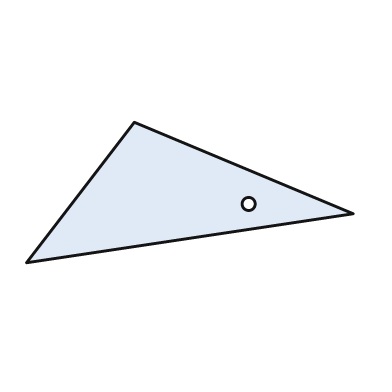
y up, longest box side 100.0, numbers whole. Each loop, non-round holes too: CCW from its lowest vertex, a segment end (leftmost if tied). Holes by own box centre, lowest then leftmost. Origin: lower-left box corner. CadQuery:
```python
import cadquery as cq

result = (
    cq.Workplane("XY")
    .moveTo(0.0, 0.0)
    .lineTo(100.0, 15.0)
    .lineTo(33.0, 43.0)
    .close()
    .moveTo(68.0, 18.0)
    .circle(2.0)
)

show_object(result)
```